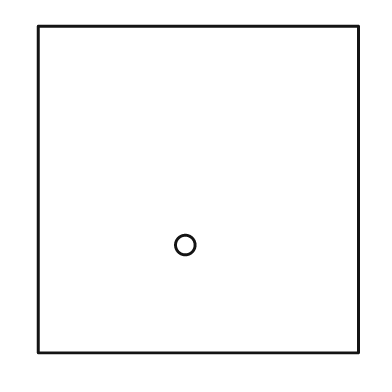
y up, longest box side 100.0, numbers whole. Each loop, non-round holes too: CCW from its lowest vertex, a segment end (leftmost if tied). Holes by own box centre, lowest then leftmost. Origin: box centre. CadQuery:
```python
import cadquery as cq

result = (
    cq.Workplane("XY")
    .moveTo(-49.0, -50.0)
    .lineTo(49.0, -50.0)
    .lineTo(49.0, 50.0)
    .lineTo(-49.0, 50.0)
    .close()
    .moveTo(-4.0, -17.0)
    .circle(3.0)
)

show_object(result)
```